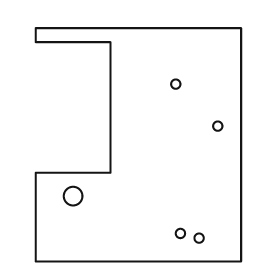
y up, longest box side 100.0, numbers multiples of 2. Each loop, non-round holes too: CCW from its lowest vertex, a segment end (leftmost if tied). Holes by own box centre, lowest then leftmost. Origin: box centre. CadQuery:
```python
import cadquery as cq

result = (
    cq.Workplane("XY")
    .moveTo(-44.0, -50.0)
    .lineTo(44.0, -50.0)
    .lineTo(44.0, 50.0)
    .lineTo(-44.0, 50.0)
    .lineTo(-44.0, 44.0)
    .lineTo(-12.0, 44.0)
    .lineTo(-12.0, -12.0)
    .lineTo(-44.0, -12.0)
    .close()
    .moveTo(26.0, -40.0)
    .circle(2.0)
    .moveTo(18.0, -38.0)
    .circle(2.0)
    .moveTo(-28.0, -22.0)
    .circle(4.0)
    .moveTo(34.0, 8.0)
    .circle(2.0)
    .moveTo(16.0, 26.0)
    .circle(2.0)
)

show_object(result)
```